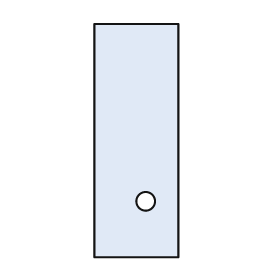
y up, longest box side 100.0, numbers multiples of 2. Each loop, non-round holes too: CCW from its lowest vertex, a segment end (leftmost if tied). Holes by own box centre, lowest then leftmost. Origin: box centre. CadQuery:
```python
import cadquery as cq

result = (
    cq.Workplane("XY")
    .moveTo(-18.0, -50.0)
    .lineTo(18.0, -50.0)
    .lineTo(18.0, 50.0)
    .lineTo(-18.0, 50.0)
    .close()
    .moveTo(4.0, -26.0)
    .circle(4.0)
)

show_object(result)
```